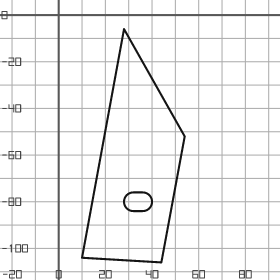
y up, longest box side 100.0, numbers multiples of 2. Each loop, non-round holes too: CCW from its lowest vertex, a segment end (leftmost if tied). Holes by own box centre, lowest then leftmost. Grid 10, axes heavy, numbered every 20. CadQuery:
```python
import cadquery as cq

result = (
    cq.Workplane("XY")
    .moveTo(44.0, -106.0)
    .lineTo(54.0, -52.0)
    .lineTo(28.0, -6.0)
    .lineTo(10.0, -104.0)
    .close()
    .moveTo(32.0, -84.0)
    .lineTo(36.0, -84.0)
    .threePointArc((40.0, -80.0), (36.0, -76.0))
    .lineTo(32.0, -76.0)
    .threePointArc((28.0, -80.0), (32.0, -84.0))
    .close()
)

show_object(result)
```